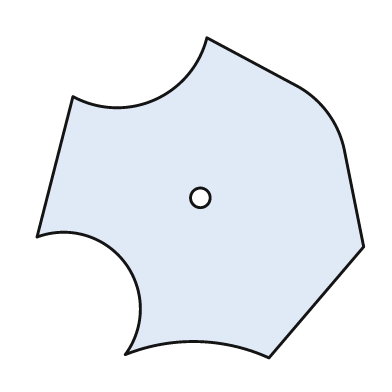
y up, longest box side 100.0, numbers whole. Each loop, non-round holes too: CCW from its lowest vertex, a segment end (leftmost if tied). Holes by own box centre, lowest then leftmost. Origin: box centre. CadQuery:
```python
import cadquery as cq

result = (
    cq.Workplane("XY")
    .moveTo(21.0, -49.0)
    .lineTo(50.0, -15.0)
    .lineTo(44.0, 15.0)
    .threePointArc((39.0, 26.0), (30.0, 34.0))
    .lineTo(2.0, 49.0)
    .threePointArc((-14.0, 30.0), (-39.0, 31.0))
    .lineTo(-50.0, -12.0)
    .threePointArc((-23.0, -20.0), (-23.0, -48.0))
    .threePointArc((-1.0, -44.0), (21.0, -49.0))
    .close()
    .moveTo(0.0, 0.0)
    .circle(3.0)
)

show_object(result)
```